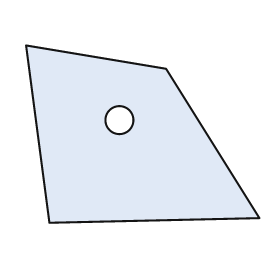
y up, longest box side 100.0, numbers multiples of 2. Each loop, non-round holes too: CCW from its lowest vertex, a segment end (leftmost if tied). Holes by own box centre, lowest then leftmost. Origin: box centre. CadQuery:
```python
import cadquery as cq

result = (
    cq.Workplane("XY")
    .moveTo(-40.0, -38.0)
    .lineTo(50.0, -36.0)
    .lineTo(10.0, 28.0)
    .lineTo(-50.0, 38.0)
    .close()
    .moveTo(-10.0, 6.0)
    .circle(6.0)
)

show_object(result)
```